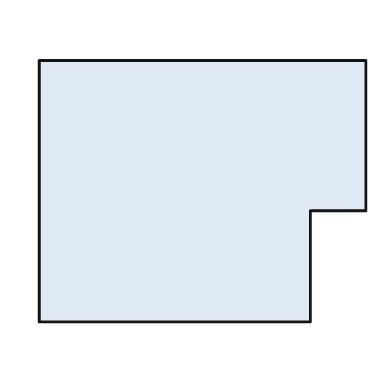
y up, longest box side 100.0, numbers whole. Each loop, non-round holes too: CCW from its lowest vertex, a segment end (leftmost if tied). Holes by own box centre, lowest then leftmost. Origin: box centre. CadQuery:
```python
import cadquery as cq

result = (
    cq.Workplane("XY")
    .moveTo(-50.0, -40.0)
    .lineTo(33.0, -40.0)
    .lineTo(33.0, -6.0)
    .lineTo(50.0, -6.0)
    .lineTo(50.0, 40.0)
    .lineTo(-50.0, 40.0)
    .close()
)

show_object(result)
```